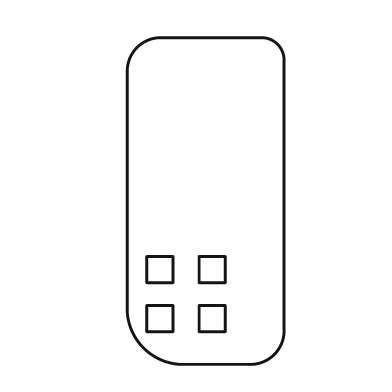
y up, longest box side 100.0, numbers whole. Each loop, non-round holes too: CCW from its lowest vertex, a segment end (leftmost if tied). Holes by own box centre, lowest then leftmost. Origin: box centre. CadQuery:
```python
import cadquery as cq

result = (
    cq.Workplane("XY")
    .moveTo(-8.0, -50.0)
    .lineTo(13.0, -50.0)
    .threePointArc((21.0, -47.0), (24.0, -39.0))
    .lineTo(24.0, 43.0)
    .threePointArc((22.0, 48.0), (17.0, 50.0))
    .lineTo(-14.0, 50.0)
    .threePointArc((-21.0, 47.0), (-24.0, 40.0))
    .lineTo(-24.0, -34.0)
    .threePointArc((-19.0, -45.0), (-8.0, -50.0))
    .close()
    .moveTo(-18.0, -40.0)
    .lineTo(-10.0, -40.0)
    .lineTo(-10.0, -32.0)
    .lineTo(-18.0, -32.0)
    .close()
    .moveTo(-2.0, -40.0)
    .lineTo(6.0, -40.0)
    .lineTo(6.0, -32.0)
    .lineTo(-2.0, -32.0)
    .close()
    .moveTo(-18.0, -25.0)
    .lineTo(-10.0, -25.0)
    .lineTo(-10.0, -17.0)
    .lineTo(-18.0, -17.0)
    .close()
    .moveTo(-2.0, -25.0)
    .lineTo(6.0, -25.0)
    .lineTo(6.0, -17.0)
    .lineTo(-2.0, -17.0)
    .close()
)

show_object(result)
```